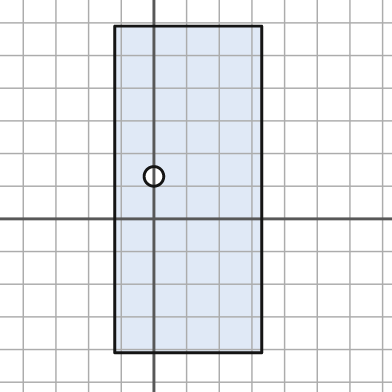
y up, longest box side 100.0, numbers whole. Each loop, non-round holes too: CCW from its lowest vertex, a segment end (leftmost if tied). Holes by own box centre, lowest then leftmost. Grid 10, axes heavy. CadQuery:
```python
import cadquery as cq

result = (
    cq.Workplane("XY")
    .moveTo(-12.0, -41.0)
    .lineTo(33.0, -41.0)
    .lineTo(33.0, 59.0)
    .lineTo(-12.0, 59.0)
    .close()
    .moveTo(0.0, 13.0)
    .circle(3.0)
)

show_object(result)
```